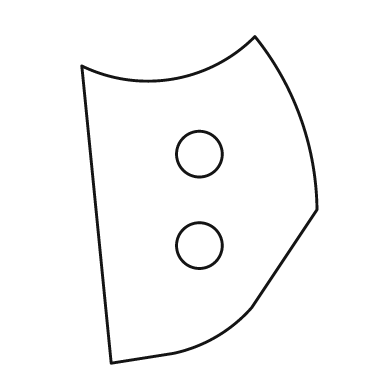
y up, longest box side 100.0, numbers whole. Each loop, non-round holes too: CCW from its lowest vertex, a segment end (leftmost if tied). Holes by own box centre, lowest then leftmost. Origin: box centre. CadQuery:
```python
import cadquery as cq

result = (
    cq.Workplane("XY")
    .moveTo(-27.0, -50.0)
    .lineTo(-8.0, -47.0)
    .threePointArc((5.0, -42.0), (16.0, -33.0))
    .lineTo(36.0, -3.0)
    .threePointArc((31.0, 25.0), (17.0, 50.0))
    .threePointArc((-8.0, 37.0), (-36.0, 41.0))
    .close()
    .moveTo(0.0, -14.0)
    .circle(7.0)
    .moveTo(0.0, 14.0)
    .circle(7.0)
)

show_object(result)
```